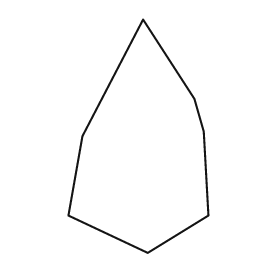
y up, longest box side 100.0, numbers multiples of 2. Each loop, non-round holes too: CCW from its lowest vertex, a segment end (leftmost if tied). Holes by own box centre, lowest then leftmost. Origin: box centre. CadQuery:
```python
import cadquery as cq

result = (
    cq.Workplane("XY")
    .moveTo(4.0, -50.0)
    .lineTo(30.0, -34.0)
    .lineTo(28.0, 2.0)
    .lineTo(24.0, 16.0)
    .lineTo(2.0, 50.0)
    .lineTo(-24.0, 0.0)
    .lineTo(-30.0, -34.0)
    .close()
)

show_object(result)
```